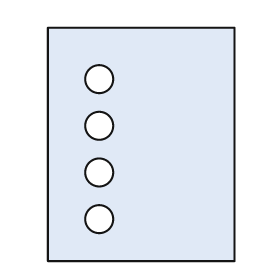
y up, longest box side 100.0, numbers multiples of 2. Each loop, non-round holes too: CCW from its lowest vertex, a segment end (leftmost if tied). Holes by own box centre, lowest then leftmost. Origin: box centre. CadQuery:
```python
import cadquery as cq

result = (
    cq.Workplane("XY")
    .moveTo(-40.0, -50.0)
    .lineTo(40.0, -50.0)
    .lineTo(40.0, 50.0)
    .lineTo(-40.0, 50.0)
    .close()
    .moveTo(-18.0, -32.0)
    .circle(6.0)
    .moveTo(-18.0, -12.0)
    .circle(6.0)
    .moveTo(-18.0, 8.0)
    .circle(6.0)
    .moveTo(-18.0, 28.0)
    .circle(6.0)
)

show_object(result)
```